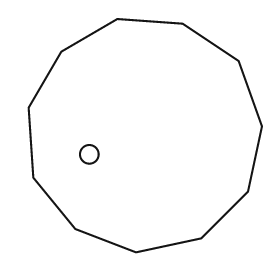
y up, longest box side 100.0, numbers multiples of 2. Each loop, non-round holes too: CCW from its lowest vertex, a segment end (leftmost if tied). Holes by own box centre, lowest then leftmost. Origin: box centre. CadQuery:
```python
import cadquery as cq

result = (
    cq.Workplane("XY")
    .moveTo(-4.0, -50.0)
    .lineTo(24.0, -44.0)
    .lineTo(44.0, -24.0)
    .lineTo(50.0, 4.0)
    .lineTo(40.0, 32.0)
    .lineTo(16.0, 48.0)
    .lineTo(-12.0, 50.0)
    .lineTo(-36.0, 36.0)
    .lineTo(-50.0, 12.0)
    .lineTo(-48.0, -18.0)
    .lineTo(-30.0, -40.0)
    .close()
    .moveTo(-24.0, -8.0)
    .circle(4.0)
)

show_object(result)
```